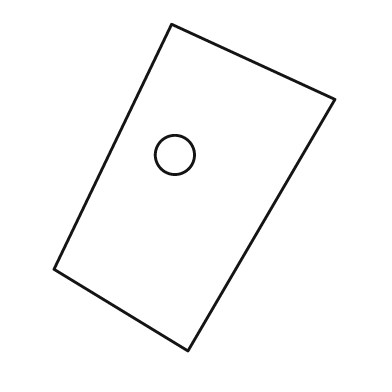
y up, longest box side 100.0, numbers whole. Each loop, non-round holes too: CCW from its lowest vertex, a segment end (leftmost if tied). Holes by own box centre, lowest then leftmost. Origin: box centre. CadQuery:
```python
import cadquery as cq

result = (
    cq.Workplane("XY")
    .moveTo(-2.0, -50.0)
    .lineTo(43.0, 27.0)
    .lineTo(-7.0, 50.0)
    .lineTo(-43.0, -25.0)
    .close()
    .moveTo(-6.0, 10.0)
    .circle(6.0)
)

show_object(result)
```